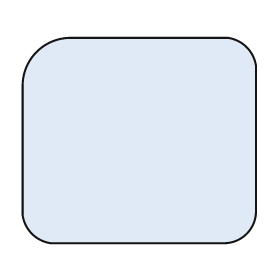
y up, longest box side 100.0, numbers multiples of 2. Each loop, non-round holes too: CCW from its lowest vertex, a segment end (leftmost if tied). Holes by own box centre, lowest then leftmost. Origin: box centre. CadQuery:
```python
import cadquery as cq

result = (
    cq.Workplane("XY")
    .moveTo(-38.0, -44.0)
    .lineTo(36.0, -44.0)
    .threePointArc((46.0, -40.0), (50.0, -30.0))
    .lineTo(50.0, 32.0)
    .threePointArc((46.0, 40.0), (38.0, 44.0))
    .lineTo(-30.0, 44.0)
    .threePointArc((-44.0, 38.0), (-50.0, 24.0))
    .lineTo(-50.0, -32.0)
    .threePointArc((-46.0, -40.0), (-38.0, -44.0))
    .close()
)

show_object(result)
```